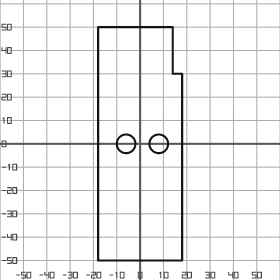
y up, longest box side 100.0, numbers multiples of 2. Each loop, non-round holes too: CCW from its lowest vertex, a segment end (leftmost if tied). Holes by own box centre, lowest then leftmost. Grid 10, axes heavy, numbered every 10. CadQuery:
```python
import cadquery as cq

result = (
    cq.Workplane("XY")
    .moveTo(-18.0, -50.0)
    .lineTo(18.0, -50.0)
    .lineTo(18.0, 30.0)
    .lineTo(14.0, 30.0)
    .lineTo(14.0, 50.0)
    .lineTo(-18.0, 50.0)
    .close()
    .moveTo(-6.0, 0.0)
    .circle(4.0)
    .moveTo(8.0, 0.0)
    .circle(4.0)
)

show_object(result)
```